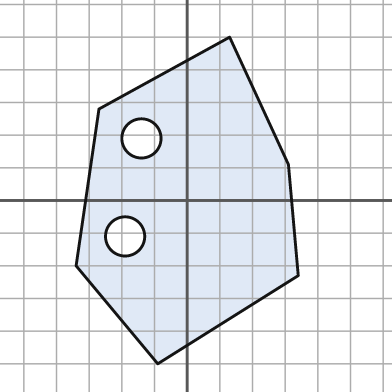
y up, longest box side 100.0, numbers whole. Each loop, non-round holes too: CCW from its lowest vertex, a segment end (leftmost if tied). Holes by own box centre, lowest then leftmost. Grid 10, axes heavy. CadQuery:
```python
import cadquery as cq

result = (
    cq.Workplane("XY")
    .moveTo(-9.0, -50.0)
    .lineTo(34.0, -23.0)
    .lineTo(31.0, 11.0)
    .lineTo(13.0, 50.0)
    .lineTo(-27.0, 28.0)
    .lineTo(-34.0, -20.0)
    .close()
    .moveTo(-19.0, -11.0)
    .circle(6.0)
    .moveTo(-14.0, 19.0)
    .circle(6.0)
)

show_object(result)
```